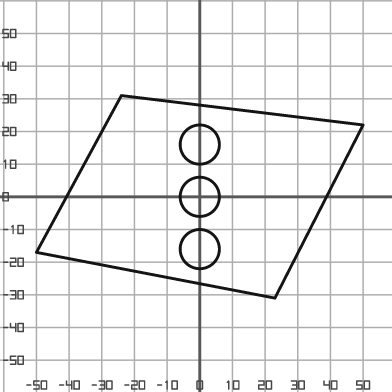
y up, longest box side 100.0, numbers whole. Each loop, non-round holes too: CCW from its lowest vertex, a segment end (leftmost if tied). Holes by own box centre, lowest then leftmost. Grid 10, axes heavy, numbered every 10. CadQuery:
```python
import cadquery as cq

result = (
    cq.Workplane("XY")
    .moveTo(23.0, -31.0)
    .lineTo(50.0, 22.0)
    .lineTo(-24.0, 31.0)
    .lineTo(-50.0, -17.0)
    .close()
    .moveTo(0.0, -16.0)
    .circle(6.0)
    .moveTo(0.0, 0.0)
    .circle(6.0)
    .moveTo(0.0, 16.0)
    .circle(6.0)
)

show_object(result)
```